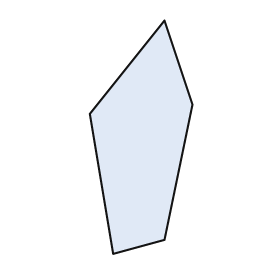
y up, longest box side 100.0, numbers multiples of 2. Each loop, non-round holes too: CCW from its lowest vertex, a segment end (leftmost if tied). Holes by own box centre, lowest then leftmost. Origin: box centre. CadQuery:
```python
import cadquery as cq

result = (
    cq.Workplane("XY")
    .moveTo(-12.0, -50.0)
    .lineTo(10.0, -44.0)
    .lineTo(22.0, 14.0)
    .lineTo(10.0, 50.0)
    .lineTo(-22.0, 10.0)
    .close()
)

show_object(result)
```